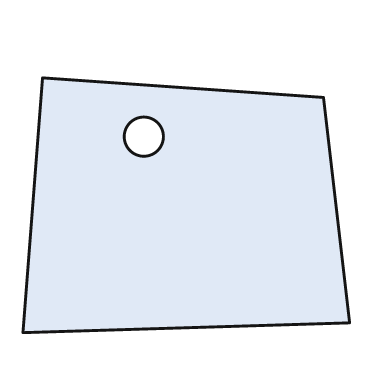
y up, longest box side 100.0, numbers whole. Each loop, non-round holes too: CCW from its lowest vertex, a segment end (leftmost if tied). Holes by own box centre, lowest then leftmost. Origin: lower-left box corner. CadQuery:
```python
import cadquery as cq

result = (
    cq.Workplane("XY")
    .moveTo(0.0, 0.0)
    .lineTo(100.0, 3.0)
    .lineTo(92.0, 72.0)
    .lineTo(6.0, 78.0)
    .close()
    .moveTo(37.0, 60.0)
    .circle(6.0)
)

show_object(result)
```